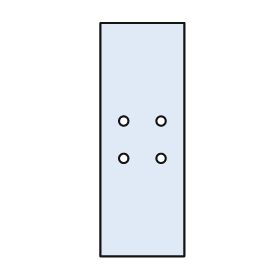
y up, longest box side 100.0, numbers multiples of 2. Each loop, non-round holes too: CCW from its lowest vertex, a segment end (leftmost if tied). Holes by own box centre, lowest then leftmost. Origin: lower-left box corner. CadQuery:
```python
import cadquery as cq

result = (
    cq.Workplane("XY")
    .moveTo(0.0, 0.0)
    .lineTo(36.0, 0.0)
    .lineTo(36.0, 100.0)
    .lineTo(0.0, 100.0)
    .close()
    .moveTo(10.0, 42.0)
    .circle(2.0)
    .moveTo(26.0, 42.0)
    .circle(2.0)
    .moveTo(10.0, 58.0)
    .circle(2.0)
    .moveTo(26.0, 58.0)
    .circle(2.0)
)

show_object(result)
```